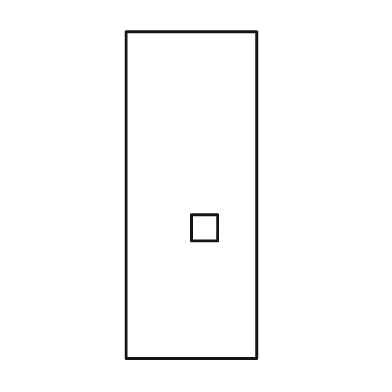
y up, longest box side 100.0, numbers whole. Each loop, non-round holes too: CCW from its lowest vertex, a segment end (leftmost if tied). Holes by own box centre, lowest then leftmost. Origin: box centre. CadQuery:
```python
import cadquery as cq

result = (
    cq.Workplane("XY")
    .moveTo(-20.0, -50.0)
    .lineTo(20.0, -50.0)
    .lineTo(20.0, 50.0)
    .lineTo(-20.0, 50.0)
    .close()
    .moveTo(0.0, -14.0)
    .lineTo(8.0, -14.0)
    .lineTo(8.0, -6.0)
    .lineTo(0.0, -6.0)
    .close()
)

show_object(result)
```